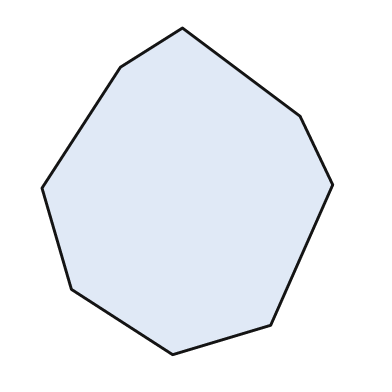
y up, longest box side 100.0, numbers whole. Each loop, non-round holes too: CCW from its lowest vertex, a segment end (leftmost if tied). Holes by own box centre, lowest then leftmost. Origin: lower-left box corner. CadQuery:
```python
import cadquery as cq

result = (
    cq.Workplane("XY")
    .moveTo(40.0, 0.0)
    .lineTo(70.0, 9.0)
    .lineTo(89.0, 52.0)
    .lineTo(79.0, 73.0)
    .lineTo(43.0, 100.0)
    .lineTo(24.0, 88.0)
    .lineTo(0.0, 51.0)
    .lineTo(9.0, 20.0)
    .close()
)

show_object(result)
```